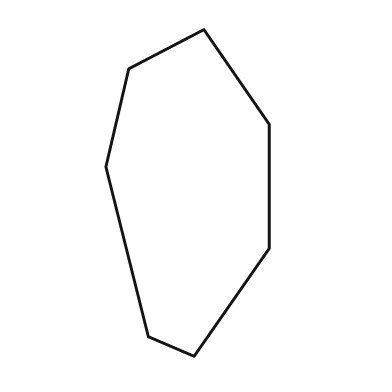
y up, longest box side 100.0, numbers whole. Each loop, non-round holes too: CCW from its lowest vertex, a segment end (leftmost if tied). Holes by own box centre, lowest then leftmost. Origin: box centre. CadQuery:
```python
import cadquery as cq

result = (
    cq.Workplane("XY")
    .moveTo(2.0, -50.0)
    .lineTo(25.0, -17.0)
    .lineTo(25.0, 21.0)
    .lineTo(5.0, 50.0)
    .lineTo(-18.0, 38.0)
    .lineTo(-25.0, 8.0)
    .lineTo(-12.0, -44.0)
    .close()
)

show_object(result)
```